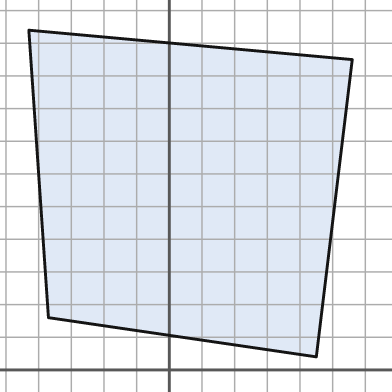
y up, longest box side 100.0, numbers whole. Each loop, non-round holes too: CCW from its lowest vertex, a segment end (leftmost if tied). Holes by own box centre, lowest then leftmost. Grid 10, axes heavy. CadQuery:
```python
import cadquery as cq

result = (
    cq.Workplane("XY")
    .moveTo(45.0, 4.0)
    .lineTo(56.0, 95.0)
    .lineTo(-43.0, 104.0)
    .lineTo(-37.0, 16.0)
    .close()
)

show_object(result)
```